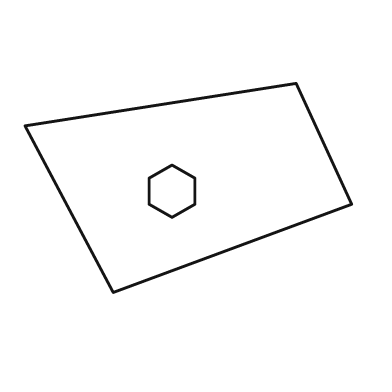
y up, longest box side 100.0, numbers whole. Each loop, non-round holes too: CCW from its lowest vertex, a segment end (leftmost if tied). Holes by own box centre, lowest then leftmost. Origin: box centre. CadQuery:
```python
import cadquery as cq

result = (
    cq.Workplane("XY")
    .moveTo(-23.0, -32.0)
    .lineTo(50.0, -5.0)
    .lineTo(33.0, 32.0)
    .lineTo(-50.0, 19.0)
    .close()
    .moveTo(-5.0, -9.0)
    .lineTo(2.0, -5.0)
    .lineTo(2.0, 3.0)
    .lineTo(-5.0, 7.0)
    .lineTo(-12.0, 3.0)
    .lineTo(-12.0, -5.0)
    .close()
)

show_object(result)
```